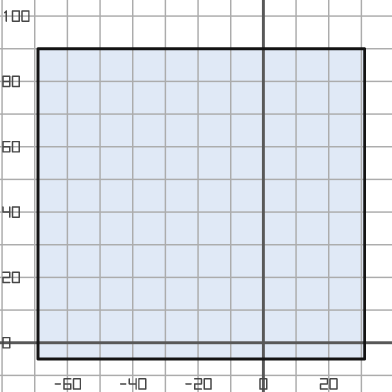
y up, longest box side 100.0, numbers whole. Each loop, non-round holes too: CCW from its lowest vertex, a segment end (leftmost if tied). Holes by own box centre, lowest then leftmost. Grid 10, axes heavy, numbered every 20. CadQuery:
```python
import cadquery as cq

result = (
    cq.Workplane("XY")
    .moveTo(-69.0, -5.0)
    .lineTo(31.0, -5.0)
    .lineTo(31.0, 90.0)
    .lineTo(-69.0, 90.0)
    .close()
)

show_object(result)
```